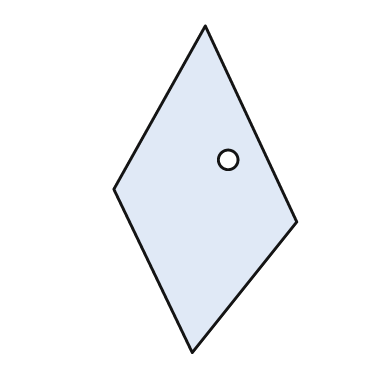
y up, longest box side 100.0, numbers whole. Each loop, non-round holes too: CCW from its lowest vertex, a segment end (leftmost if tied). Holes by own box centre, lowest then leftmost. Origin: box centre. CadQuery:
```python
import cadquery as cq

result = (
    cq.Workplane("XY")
    .moveTo(-4.0, -50.0)
    .lineTo(28.0, -10.0)
    .lineTo(0.0, 50.0)
    .lineTo(-28.0, 0.0)
    .close()
    .moveTo(7.0, 9.0)
    .circle(3.0)
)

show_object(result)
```